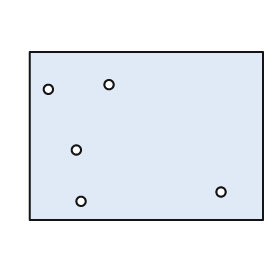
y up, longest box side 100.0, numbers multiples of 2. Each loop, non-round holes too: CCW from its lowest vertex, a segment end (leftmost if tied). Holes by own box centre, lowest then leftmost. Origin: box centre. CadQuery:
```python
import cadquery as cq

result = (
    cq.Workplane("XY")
    .moveTo(-50.0, -36.0)
    .lineTo(50.0, -36.0)
    .lineTo(50.0, 36.0)
    .lineTo(-50.0, 36.0)
    .close()
    .moveTo(-28.0, -28.0)
    .circle(2.0)
    .moveTo(32.0, -24.0)
    .circle(2.0)
    .moveTo(-30.0, -6.0)
    .circle(2.0)
    .moveTo(-42.0, 20.0)
    .circle(2.0)
    .moveTo(-16.0, 22.0)
    .circle(2.0)
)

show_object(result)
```